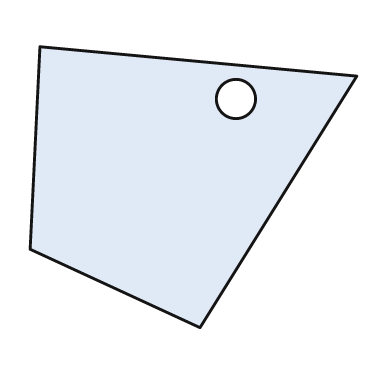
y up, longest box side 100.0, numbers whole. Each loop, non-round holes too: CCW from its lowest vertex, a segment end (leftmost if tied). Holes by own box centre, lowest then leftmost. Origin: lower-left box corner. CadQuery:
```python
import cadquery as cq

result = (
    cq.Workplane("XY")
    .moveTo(52.0, 0.0)
    .lineTo(100.0, 77.0)
    .lineTo(3.0, 86.0)
    .lineTo(0.0, 24.0)
    .close()
    .moveTo(63.0, 70.0)
    .circle(6.0)
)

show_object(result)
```